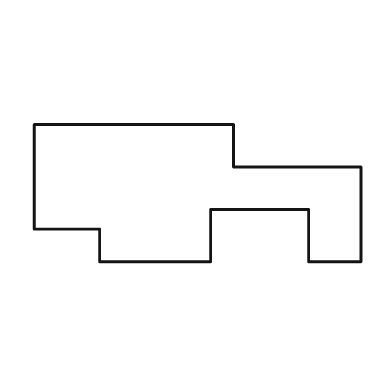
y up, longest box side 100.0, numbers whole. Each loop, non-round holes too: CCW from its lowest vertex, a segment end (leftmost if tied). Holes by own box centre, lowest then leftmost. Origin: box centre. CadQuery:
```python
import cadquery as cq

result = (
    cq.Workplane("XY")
    .moveTo(-30.0, -21.0)
    .lineTo(4.0, -21.0)
    .lineTo(4.0, -5.0)
    .lineTo(34.0, -5.0)
    .lineTo(34.0, -21.0)
    .lineTo(50.0, -21.0)
    .lineTo(50.0, 8.0)
    .lineTo(11.0, 8.0)
    .lineTo(11.0, 21.0)
    .lineTo(-50.0, 21.0)
    .lineTo(-50.0, -11.0)
    .lineTo(-30.0, -11.0)
    .close()
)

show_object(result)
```